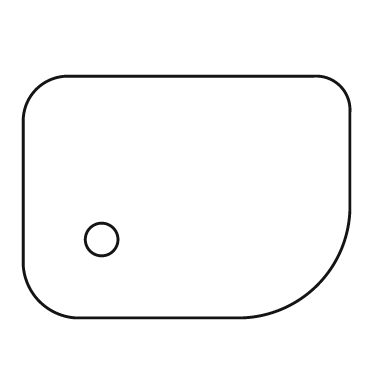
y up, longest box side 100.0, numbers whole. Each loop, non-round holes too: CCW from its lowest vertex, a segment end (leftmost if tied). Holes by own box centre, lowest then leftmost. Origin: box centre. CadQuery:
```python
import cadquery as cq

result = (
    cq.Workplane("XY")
    .moveTo(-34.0, -37.0)
    .lineTo(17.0, -37.0)
    .threePointArc((40.0, -27.0), (50.0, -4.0))
    .lineTo(50.0, 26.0)
    .threePointArc((47.0, 34.0), (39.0, 37.0))
    .lineTo(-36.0, 37.0)
    .threePointArc((-46.0, 33.0), (-50.0, 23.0))
    .lineTo(-50.0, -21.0)
    .threePointArc((-45.0, -32.0), (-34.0, -37.0))
    .close()
    .moveTo(-26.0, -13.0)
    .circle(5.0)
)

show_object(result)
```